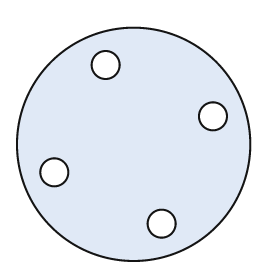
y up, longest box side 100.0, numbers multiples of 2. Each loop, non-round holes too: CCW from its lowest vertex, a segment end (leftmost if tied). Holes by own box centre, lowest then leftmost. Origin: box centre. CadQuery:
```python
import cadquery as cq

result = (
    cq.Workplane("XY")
    .moveTo(0.0, 0.0)
    .circle(50.0)
    .moveTo(12.0, -34.0)
    .circle(6.0)
    .moveTo(-34.0, -12.0)
    .circle(6.0)
    .moveTo(34.0, 12.0)
    .circle(6.0)
    .moveTo(-12.0, 34.0)
    .circle(6.0)
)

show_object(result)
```